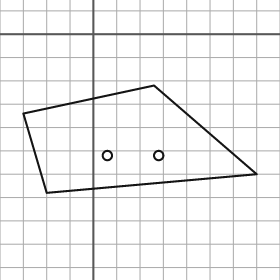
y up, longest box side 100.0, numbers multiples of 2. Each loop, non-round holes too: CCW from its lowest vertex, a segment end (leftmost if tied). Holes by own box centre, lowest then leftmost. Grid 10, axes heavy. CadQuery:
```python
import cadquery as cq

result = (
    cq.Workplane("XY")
    .moveTo(-20.0, -68.0)
    .lineTo(70.0, -60.0)
    .lineTo(26.0, -22.0)
    .lineTo(-30.0, -34.0)
    .close()
    .moveTo(6.0, -52.0)
    .circle(2.0)
    .moveTo(28.0, -52.0)
    .circle(2.0)
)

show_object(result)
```